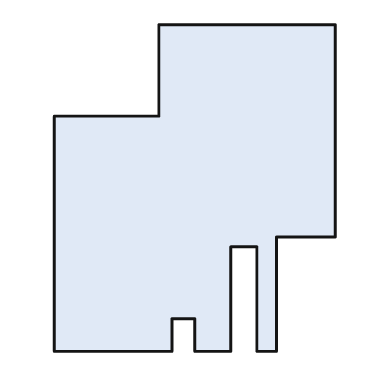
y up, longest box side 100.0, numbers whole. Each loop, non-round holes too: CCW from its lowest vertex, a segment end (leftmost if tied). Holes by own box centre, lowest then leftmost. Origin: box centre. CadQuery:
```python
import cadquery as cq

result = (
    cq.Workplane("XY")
    .moveTo(-43.0, -50.0)
    .lineTo(-7.0, -50.0)
    .lineTo(-7.0, -40.0)
    .lineTo(0.0, -40.0)
    .lineTo(0.0, -50.0)
    .lineTo(11.0, -50.0)
    .lineTo(11.0, -18.0)
    .lineTo(19.0, -18.0)
    .lineTo(19.0, -50.0)
    .lineTo(25.0, -50.0)
    .lineTo(25.0, -15.0)
    .lineTo(43.0, -15.0)
    .lineTo(43.0, 50.0)
    .lineTo(-11.0, 50.0)
    .lineTo(-11.0, 22.0)
    .lineTo(-43.0, 22.0)
    .close()
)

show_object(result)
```